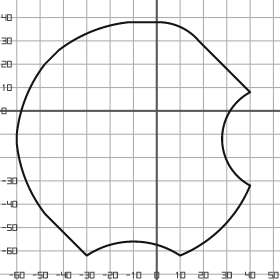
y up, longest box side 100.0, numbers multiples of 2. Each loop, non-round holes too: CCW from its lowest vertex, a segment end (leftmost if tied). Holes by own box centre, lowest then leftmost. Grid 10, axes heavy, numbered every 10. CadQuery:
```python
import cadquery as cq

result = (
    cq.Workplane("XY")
    .moveTo(-30.0, -62.0)
    .threePointArc((-10.0, -56.0), (10.0, -62.0))
    .threePointArc((28.0, -50.0), (40.0, -32.0))
    .threePointArc((28.0, -12.0), (40.0, 8.0))
    .lineTo(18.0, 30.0)
    .threePointArc((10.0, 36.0), (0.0, 38.0))
    .lineTo(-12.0, 38.0)
    .threePointArc((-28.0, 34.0), (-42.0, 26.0))
    .lineTo(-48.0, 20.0)
    .threePointArc((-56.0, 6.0), (-60.0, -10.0))
    .lineTo(-60.0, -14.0)
    .threePointArc((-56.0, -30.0), (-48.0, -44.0))
    .close()
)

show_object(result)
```